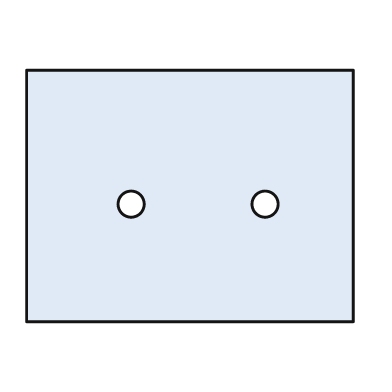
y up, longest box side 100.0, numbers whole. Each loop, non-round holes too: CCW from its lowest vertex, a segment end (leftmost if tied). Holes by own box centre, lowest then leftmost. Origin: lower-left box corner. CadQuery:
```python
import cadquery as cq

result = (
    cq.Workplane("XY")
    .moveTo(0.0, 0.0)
    .lineTo(100.0, 0.0)
    .lineTo(100.0, 77.0)
    .lineTo(0.0, 77.0)
    .close()
    .moveTo(32.0, 36.0)
    .circle(4.0)
    .moveTo(73.0, 36.0)
    .circle(4.0)
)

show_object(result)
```